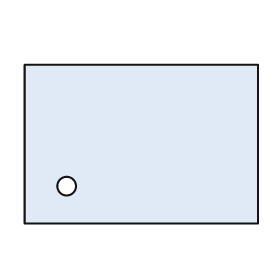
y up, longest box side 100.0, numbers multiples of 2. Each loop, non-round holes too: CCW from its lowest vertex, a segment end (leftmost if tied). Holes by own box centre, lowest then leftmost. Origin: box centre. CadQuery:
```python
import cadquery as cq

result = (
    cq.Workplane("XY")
    .moveTo(-50.0, -34.0)
    .lineTo(50.0, -34.0)
    .lineTo(50.0, 34.0)
    .lineTo(-50.0, 34.0)
    .close()
    .moveTo(-32.0, -18.0)
    .circle(4.0)
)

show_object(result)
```